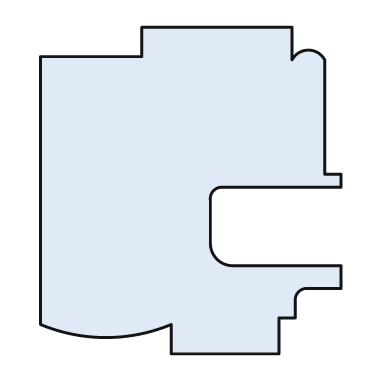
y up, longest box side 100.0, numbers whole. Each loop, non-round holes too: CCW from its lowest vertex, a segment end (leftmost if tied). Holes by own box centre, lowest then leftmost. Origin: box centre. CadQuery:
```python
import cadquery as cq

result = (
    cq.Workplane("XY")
    .moveTo(-6.0, -50.0)
    .lineTo(27.0, -50.0)
    .lineTo(27.0, -39.0)
    .lineTo(32.0, -39.0)
    .lineTo(32.0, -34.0)
    .threePointArc((33.0, -31.0), (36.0, -30.0))
    .lineTo(46.0, -30.0)
    .lineTo(46.0, -23.0)
    .lineTo(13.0, -23.0)
    .threePointArc((8.0, -21.0), (6.0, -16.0))
    .lineTo(6.0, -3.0)
    .threePointArc((7.0, 0.0), (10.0, 1.0))
    .lineTo(46.0, 1.0)
    .lineTo(46.0, 5.0)
    .lineTo(41.0, 5.0)
    .lineTo(41.0, 40.0)
    .threePointArc((36.0, 43.0), (31.0, 40.0))
    .lineTo(31.0, 50.0)
    .lineTo(-15.0, 50.0)
    .lineTo(-15.0, 41.0)
    .lineTo(-46.0, 41.0)
    .lineTo(-46.0, -41.0)
    .threePointArc((-26.0, -45.0), (-6.0, -41.0))
    .close()
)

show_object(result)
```